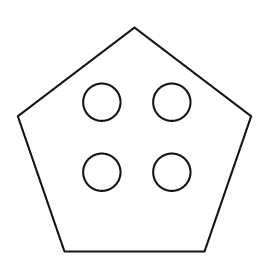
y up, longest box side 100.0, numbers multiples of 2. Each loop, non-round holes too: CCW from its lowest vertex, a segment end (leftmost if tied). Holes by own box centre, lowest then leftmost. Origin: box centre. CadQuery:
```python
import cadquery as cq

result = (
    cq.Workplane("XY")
    .moveTo(-30.0, -48.0)
    .lineTo(30.0, -48.0)
    .lineTo(50.0, 10.0)
    .lineTo(0.0, 48.0)
    .lineTo(-50.0, 10.0)
    .close()
    .moveTo(-14.0, -14.0)
    .circle(8.0)
    .moveTo(16.0, -14.0)
    .circle(8.0)
    .moveTo(-14.0, 16.0)
    .circle(8.0)
    .moveTo(16.0, 16.0)
    .circle(8.0)
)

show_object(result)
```